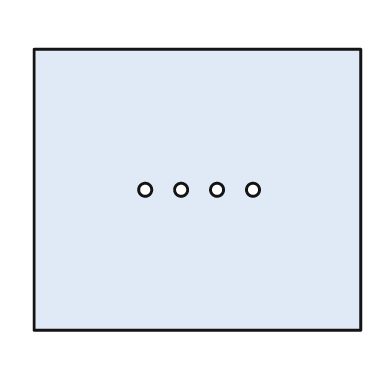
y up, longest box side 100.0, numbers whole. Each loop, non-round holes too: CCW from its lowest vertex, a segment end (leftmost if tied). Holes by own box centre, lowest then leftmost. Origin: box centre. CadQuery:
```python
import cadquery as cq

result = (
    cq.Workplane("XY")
    .moveTo(-50.0, -43.0)
    .lineTo(50.0, -43.0)
    .lineTo(50.0, 43.0)
    .lineTo(-50.0, 43.0)
    .close()
    .moveTo(-16.0, 0.0)
    .circle(2.0)
    .moveTo(-5.0, 0.0)
    .circle(2.0)
    .moveTo(6.0, 0.0)
    .circle(2.0)
    .moveTo(17.0, 0.0)
    .circle(2.0)
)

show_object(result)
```